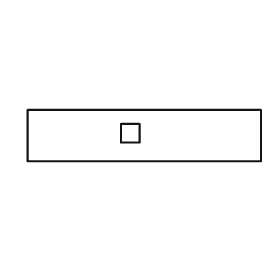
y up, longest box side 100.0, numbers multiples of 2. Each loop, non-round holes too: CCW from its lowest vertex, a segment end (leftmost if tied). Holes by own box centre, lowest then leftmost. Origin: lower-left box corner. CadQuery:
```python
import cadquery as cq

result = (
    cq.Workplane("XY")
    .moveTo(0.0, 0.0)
    .lineTo(100.0, 0.0)
    .lineTo(100.0, 22.0)
    .lineTo(0.0, 22.0)
    .close()
    .moveTo(40.0, 8.0)
    .lineTo(48.0, 8.0)
    .lineTo(48.0, 16.0)
    .lineTo(40.0, 16.0)
    .close()
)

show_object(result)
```